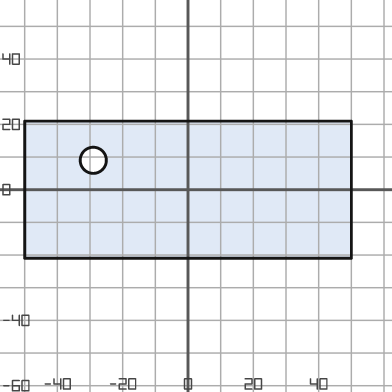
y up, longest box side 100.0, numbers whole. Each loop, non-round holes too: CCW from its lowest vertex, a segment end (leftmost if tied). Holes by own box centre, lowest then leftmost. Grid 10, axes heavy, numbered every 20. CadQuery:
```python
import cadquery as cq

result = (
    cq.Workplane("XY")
    .moveTo(-50.0, -21.0)
    .lineTo(50.0, -21.0)
    .lineTo(50.0, 21.0)
    .lineTo(-50.0, 21.0)
    .close()
    .moveTo(-29.0, 9.0)
    .circle(4.0)
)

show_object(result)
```